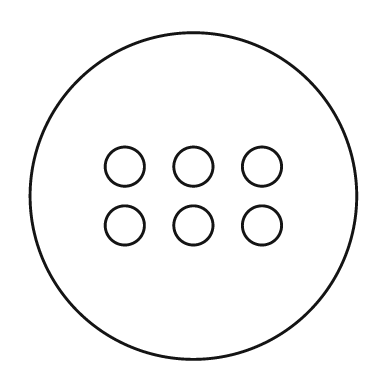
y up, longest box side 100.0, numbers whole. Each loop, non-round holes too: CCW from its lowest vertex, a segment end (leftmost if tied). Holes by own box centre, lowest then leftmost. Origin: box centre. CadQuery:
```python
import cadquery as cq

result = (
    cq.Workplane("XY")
    .moveTo(0.0, 0.0)
    .circle(50.0)
    .moveTo(-21.0, -9.0)
    .circle(6.0)
    .moveTo(0.0, -9.0)
    .circle(6.0)
    .moveTo(21.0, -9.0)
    .circle(6.0)
    .moveTo(-21.0, 9.0)
    .circle(6.0)
    .moveTo(0.0, 9.0)
    .circle(6.0)
    .moveTo(21.0, 9.0)
    .circle(6.0)
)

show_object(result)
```